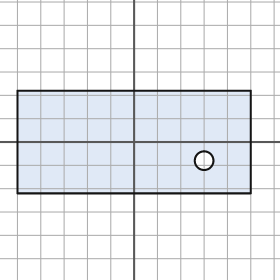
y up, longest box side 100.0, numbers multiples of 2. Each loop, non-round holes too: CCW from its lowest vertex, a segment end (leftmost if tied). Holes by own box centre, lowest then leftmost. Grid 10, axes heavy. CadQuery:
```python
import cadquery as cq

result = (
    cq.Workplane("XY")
    .moveTo(-50.0, -22.0)
    .lineTo(50.0, -22.0)
    .lineTo(50.0, 22.0)
    .lineTo(-50.0, 22.0)
    .close()
    .moveTo(30.0, -8.0)
    .circle(4.0)
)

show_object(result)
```